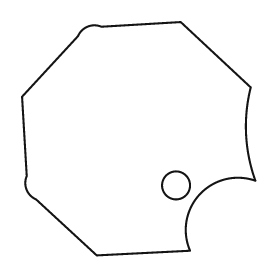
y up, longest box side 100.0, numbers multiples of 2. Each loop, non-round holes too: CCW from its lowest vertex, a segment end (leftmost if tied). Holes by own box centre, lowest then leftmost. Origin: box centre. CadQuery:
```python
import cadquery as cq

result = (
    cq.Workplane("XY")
    .moveTo(-18.0, -50.0)
    .lineTo(22.0, -48.0)
    .threePointArc((26.0, -24.0), (50.0, -18.0))
    .threePointArc((46.0, 2.0), (48.0, 22.0))
    .lineTo(18.0, 50.0)
    .lineTo(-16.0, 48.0)
    .threePointArc((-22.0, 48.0), (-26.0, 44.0))
    .lineTo(-50.0, 18.0)
    .lineTo(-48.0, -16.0)
    .threePointArc((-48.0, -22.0), (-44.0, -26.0))
    .close()
    .moveTo(16.0, -20.0)
    .circle(6.0)
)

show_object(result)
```